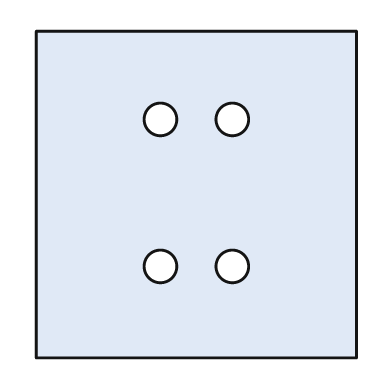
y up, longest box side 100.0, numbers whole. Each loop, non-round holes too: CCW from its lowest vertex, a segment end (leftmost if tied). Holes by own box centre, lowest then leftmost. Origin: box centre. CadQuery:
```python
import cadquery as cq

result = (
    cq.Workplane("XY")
    .moveTo(-49.0, -50.0)
    .lineTo(49.0, -50.0)
    .lineTo(49.0, 50.0)
    .lineTo(-49.0, 50.0)
    .close()
    .moveTo(-11.0, -22.0)
    .circle(5.0)
    .moveTo(11.0, -22.0)
    .circle(5.0)
    .moveTo(-11.0, 23.0)
    .circle(5.0)
    .moveTo(11.0, 23.0)
    .circle(5.0)
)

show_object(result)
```